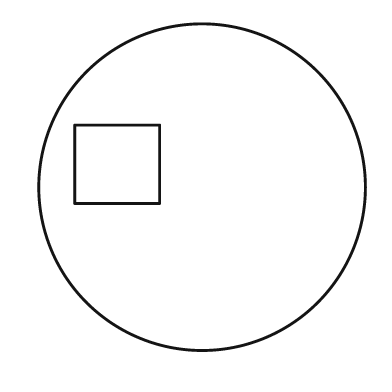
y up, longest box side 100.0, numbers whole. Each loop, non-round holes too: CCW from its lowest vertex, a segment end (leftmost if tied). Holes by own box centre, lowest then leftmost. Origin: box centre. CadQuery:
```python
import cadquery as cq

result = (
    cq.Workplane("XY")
    .moveTo(0.0, 0.0)
    .circle(50.0)
    .moveTo(-39.0, -5.0)
    .lineTo(-13.0, -5.0)
    .lineTo(-13.0, 19.0)
    .lineTo(-39.0, 19.0)
    .close()
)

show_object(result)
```